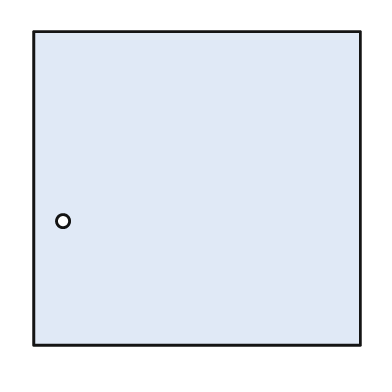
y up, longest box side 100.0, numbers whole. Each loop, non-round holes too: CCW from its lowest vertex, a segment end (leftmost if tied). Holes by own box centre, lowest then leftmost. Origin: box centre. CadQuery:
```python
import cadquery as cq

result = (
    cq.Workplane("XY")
    .moveTo(-50.0, -48.0)
    .lineTo(50.0, -48.0)
    .lineTo(50.0, 48.0)
    .lineTo(-50.0, 48.0)
    .close()
    .moveTo(-41.0, -10.0)
    .circle(2.0)
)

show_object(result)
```